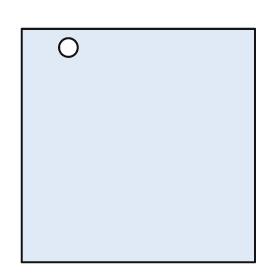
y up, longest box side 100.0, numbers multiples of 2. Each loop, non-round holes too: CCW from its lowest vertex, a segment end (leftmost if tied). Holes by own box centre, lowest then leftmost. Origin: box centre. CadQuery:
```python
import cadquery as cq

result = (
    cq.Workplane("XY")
    .moveTo(-50.0, -50.0)
    .lineTo(50.0, -50.0)
    .lineTo(50.0, 50.0)
    .lineTo(-50.0, 50.0)
    .close()
    .moveTo(-30.0, 42.0)
    .circle(4.0)
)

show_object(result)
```